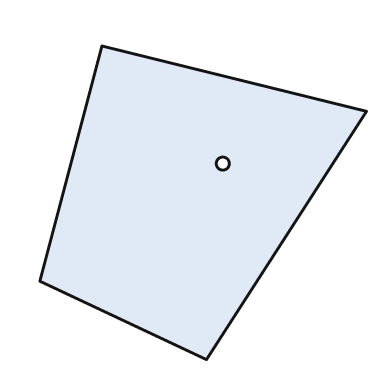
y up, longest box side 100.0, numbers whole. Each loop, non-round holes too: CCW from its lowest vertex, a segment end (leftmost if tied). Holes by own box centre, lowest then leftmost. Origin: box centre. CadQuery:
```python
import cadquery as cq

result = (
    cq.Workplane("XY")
    .moveTo(1.0, -48.0)
    .lineTo(50.0, 28.0)
    .lineTo(-31.0, 48.0)
    .lineTo(-50.0, -24.0)
    .close()
    .moveTo(6.0, 12.0)
    .circle(2.0)
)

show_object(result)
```